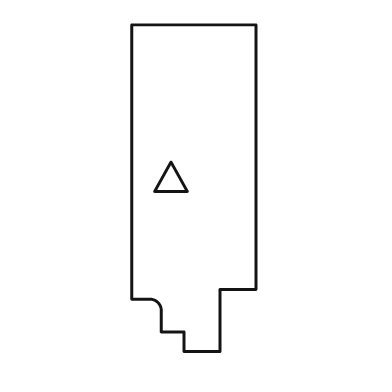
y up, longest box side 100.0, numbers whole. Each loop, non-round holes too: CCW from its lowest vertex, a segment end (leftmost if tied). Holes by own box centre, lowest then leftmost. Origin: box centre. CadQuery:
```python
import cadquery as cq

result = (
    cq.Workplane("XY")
    .moveTo(-3.0, -50.0)
    .lineTo(8.0, -50.0)
    .lineTo(8.0, -31.0)
    .lineTo(19.0, -31.0)
    .lineTo(19.0, 50.0)
    .lineTo(-19.0, 50.0)
    .lineTo(-19.0, -34.0)
    .lineTo(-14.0, -34.0)
    .threePointArc((-11.0, -35.0), (-10.0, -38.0))
    .lineTo(-10.0, -44.0)
    .lineTo(-3.0, -44.0)
    .close()
    .moveTo(-12.0, -1.0)
    .lineTo(-2.0, -1.0)
    .lineTo(-7.0, 8.0)
    .close()
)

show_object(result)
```